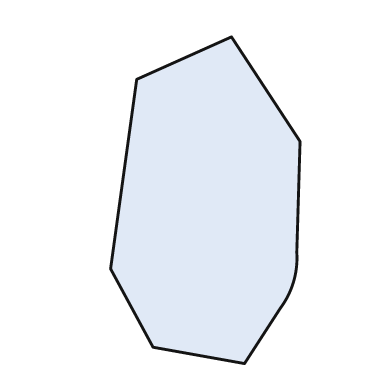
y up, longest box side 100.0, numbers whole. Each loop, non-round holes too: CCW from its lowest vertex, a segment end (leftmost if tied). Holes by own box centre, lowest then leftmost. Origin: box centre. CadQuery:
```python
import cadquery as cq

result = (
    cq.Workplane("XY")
    .moveTo(12.0, -50.0)
    .lineTo(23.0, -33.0)
    .threePointArc((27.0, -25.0), (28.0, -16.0))
    .lineTo(29.0, 18.0)
    .lineTo(8.0, 50.0)
    .lineTo(-21.0, 37.0)
    .lineTo(-29.0, -21.0)
    .lineTo(-16.0, -45.0)
    .close()
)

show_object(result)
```